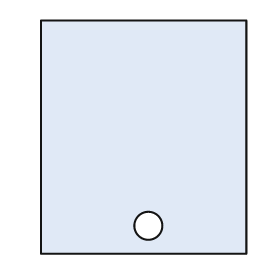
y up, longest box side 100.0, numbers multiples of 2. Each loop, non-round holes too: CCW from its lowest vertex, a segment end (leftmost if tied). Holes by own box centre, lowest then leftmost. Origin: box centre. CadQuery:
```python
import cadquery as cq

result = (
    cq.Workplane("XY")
    .moveTo(-44.0, -50.0)
    .lineTo(44.0, -50.0)
    .lineTo(44.0, 50.0)
    .lineTo(-44.0, 50.0)
    .close()
    .moveTo(2.0, -38.0)
    .circle(6.0)
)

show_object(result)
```